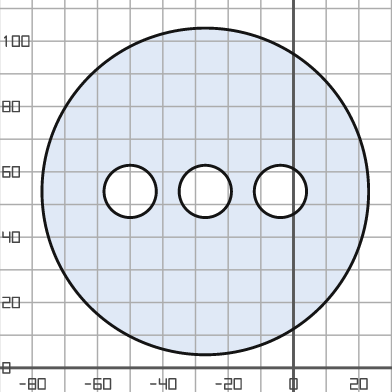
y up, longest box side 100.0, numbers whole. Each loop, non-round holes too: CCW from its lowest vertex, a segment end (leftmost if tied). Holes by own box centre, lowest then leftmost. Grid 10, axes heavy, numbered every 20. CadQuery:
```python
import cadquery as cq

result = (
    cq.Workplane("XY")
    .moveTo(-27.0, 54.0)
    .circle(50.0)
    .moveTo(-50.0, 54.0)
    .circle(8.0)
    .moveTo(-27.0, 54.0)
    .circle(8.0)
    .moveTo(-4.0, 54.0)
    .circle(8.0)
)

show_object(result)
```